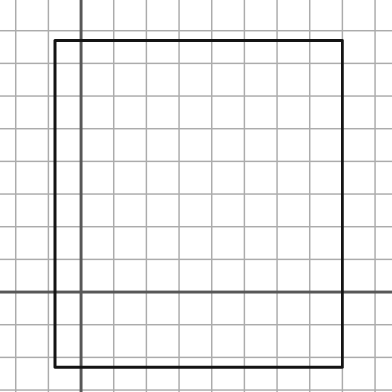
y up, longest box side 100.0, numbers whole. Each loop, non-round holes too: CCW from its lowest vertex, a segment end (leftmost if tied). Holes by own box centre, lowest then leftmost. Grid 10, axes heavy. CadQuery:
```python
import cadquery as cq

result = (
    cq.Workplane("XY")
    .moveTo(-8.0, -23.0)
    .lineTo(80.0, -23.0)
    .lineTo(80.0, 77.0)
    .lineTo(-8.0, 77.0)
    .close()
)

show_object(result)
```